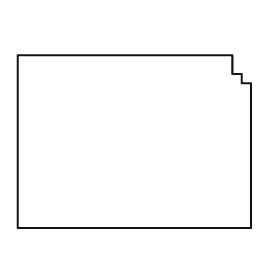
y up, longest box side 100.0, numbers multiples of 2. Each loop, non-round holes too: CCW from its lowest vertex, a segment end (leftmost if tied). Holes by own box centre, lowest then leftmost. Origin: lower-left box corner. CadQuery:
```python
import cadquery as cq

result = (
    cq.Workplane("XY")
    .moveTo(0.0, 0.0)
    .lineTo(100.0, 0.0)
    .lineTo(100.0, 62.0)
    .lineTo(96.0, 62.0)
    .lineTo(96.0, 66.0)
    .lineTo(92.0, 66.0)
    .lineTo(92.0, 74.0)
    .lineTo(0.0, 74.0)
    .close()
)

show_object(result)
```